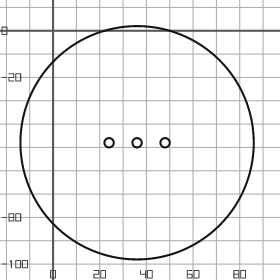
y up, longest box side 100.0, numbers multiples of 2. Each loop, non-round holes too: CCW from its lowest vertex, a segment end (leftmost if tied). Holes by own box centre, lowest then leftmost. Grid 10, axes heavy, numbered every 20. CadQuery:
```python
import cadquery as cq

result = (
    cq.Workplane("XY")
    .moveTo(36.0, -48.0)
    .circle(50.0)
    .moveTo(24.0, -48.0)
    .circle(2.0)
    .moveTo(36.0, -48.0)
    .circle(2.0)
    .moveTo(48.0, -48.0)
    .circle(2.0)
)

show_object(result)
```